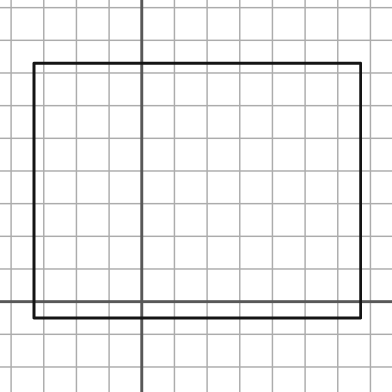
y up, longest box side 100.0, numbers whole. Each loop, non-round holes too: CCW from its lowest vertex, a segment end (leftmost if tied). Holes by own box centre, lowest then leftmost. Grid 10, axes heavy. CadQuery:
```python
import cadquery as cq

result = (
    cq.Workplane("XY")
    .moveTo(-33.0, -5.0)
    .lineTo(67.0, -5.0)
    .lineTo(67.0, 73.0)
    .lineTo(-33.0, 73.0)
    .close()
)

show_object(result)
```